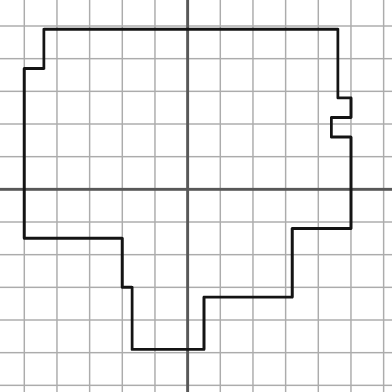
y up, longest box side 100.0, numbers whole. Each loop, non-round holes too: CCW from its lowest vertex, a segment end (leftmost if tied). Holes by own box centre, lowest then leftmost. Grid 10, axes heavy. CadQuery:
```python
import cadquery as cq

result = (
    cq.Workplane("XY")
    .moveTo(-17.0, -49.0)
    .lineTo(5.0, -49.0)
    .lineTo(5.0, -33.0)
    .lineTo(32.0, -33.0)
    .lineTo(32.0, -12.0)
    .lineTo(50.0, -12.0)
    .lineTo(50.0, 16.0)
    .lineTo(44.0, 16.0)
    .lineTo(44.0, 22.0)
    .lineTo(50.0, 22.0)
    .lineTo(50.0, 28.0)
    .lineTo(46.0, 28.0)
    .lineTo(46.0, 49.0)
    .lineTo(-44.0, 49.0)
    .lineTo(-44.0, 37.0)
    .lineTo(-50.0, 37.0)
    .lineTo(-50.0, -15.0)
    .lineTo(-20.0, -15.0)
    .lineTo(-20.0, -30.0)
    .lineTo(-17.0, -30.0)
    .close()
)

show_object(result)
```